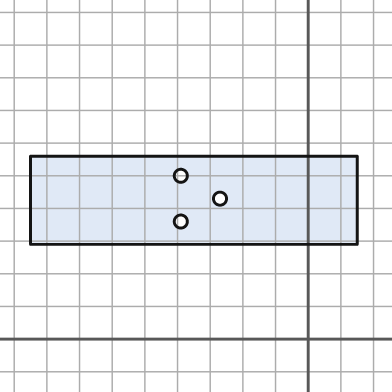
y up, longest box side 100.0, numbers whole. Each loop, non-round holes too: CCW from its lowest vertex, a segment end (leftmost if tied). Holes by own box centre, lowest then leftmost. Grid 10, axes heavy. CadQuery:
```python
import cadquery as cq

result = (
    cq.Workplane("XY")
    .moveTo(-85.0, 29.0)
    .lineTo(15.0, 29.0)
    .lineTo(15.0, 56.0)
    .lineTo(-85.0, 56.0)
    .close()
    .moveTo(-39.0, 36.0)
    .circle(2.0)
    .moveTo(-27.0, 43.0)
    .circle(2.0)
    .moveTo(-39.0, 50.0)
    .circle(2.0)
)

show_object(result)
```